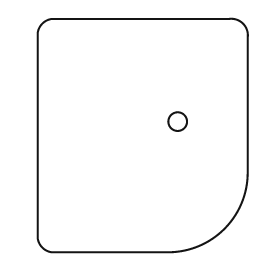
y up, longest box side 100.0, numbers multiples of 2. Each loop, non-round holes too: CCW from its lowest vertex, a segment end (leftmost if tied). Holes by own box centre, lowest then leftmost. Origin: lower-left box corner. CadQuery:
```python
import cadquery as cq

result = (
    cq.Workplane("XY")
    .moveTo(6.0, 0.0)
    .lineTo(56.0, 0.0)
    .threePointArc((80.0, 10.0), (90.0, 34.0))
    .lineTo(90.0, 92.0)
    .threePointArc((88.0, 98.0), (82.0, 100.0))
    .lineTo(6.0, 100.0)
    .threePointArc((2.0, 98.0), (0.0, 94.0))
    .lineTo(0.0, 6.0)
    .threePointArc((2.0, 2.0), (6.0, 0.0))
    .close()
    .moveTo(60.0, 56.0)
    .circle(4.0)
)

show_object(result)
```